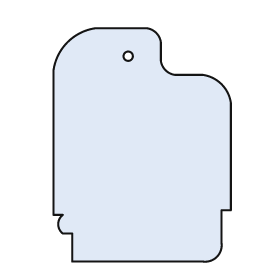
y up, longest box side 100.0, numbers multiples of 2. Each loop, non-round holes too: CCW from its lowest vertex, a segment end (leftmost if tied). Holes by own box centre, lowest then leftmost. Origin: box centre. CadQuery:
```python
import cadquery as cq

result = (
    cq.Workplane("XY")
    .moveTo(-30.0, -50.0)
    .lineTo(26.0, -50.0)
    .threePointArc((32.0, -48.0), (34.0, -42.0))
    .lineTo(34.0, -28.0)
    .lineTo(38.0, -28.0)
    .lineTo(38.0, 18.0)
    .threePointArc((34.0, 26.0), (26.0, 30.0))
    .lineTo(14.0, 30.0)
    .threePointArc((10.0, 32.0), (8.0, 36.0))
    .lineTo(8.0, 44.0)
    .threePointArc((6.0, 48.0), (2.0, 50.0))
    .lineTo(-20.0, 50.0)
    .threePointArc((-32.0, 44.0), (-38.0, 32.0))
    .lineTo(-38.0, -30.0)
    .lineTo(-34.0, -30.0)
    .threePointArc((-36.0, -34.0), (-34.0, -38.0))
    .lineTo(-30.0, -38.0)
    .close()
    .moveTo(-6.0, 38.0)
    .circle(2.0)
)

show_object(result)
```